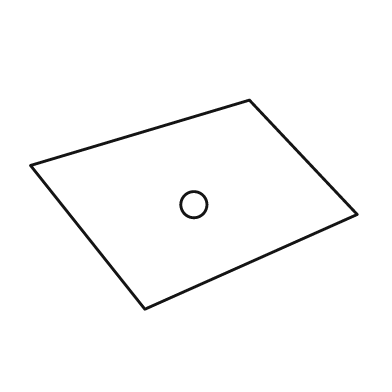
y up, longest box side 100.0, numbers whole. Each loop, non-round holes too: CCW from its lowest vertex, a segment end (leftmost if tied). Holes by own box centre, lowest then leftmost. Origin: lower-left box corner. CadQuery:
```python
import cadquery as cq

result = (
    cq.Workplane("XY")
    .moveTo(35.0, 0.0)
    .lineTo(100.0, 29.0)
    .lineTo(67.0, 64.0)
    .lineTo(0.0, 44.0)
    .close()
    .moveTo(50.0, 32.0)
    .circle(4.0)
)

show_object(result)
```